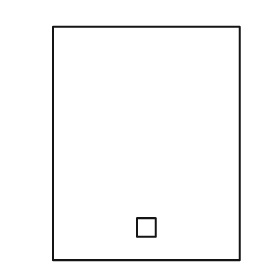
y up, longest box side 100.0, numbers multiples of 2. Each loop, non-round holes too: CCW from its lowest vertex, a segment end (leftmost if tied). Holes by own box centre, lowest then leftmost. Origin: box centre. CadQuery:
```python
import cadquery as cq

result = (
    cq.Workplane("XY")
    .moveTo(-40.0, -50.0)
    .lineTo(40.0, -50.0)
    .lineTo(40.0, 50.0)
    .lineTo(-40.0, 50.0)
    .close()
    .moveTo(-4.0, -40.0)
    .lineTo(4.0, -40.0)
    .lineTo(4.0, -32.0)
    .lineTo(-4.0, -32.0)
    .close()
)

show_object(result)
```